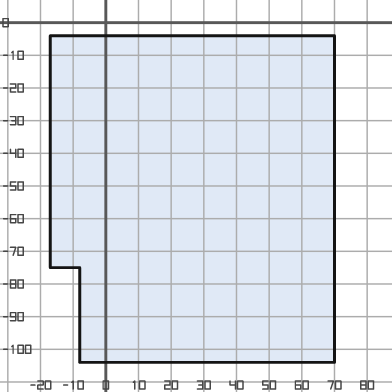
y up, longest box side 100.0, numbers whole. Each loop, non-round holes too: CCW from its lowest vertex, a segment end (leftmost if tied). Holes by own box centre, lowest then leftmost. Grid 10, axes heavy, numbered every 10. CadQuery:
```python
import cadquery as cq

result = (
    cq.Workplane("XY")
    .moveTo(-8.0, -104.0)
    .lineTo(70.0, -104.0)
    .lineTo(70.0, -4.0)
    .lineTo(-17.0, -4.0)
    .lineTo(-17.0, -75.0)
    .lineTo(-8.0, -75.0)
    .close()
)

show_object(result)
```